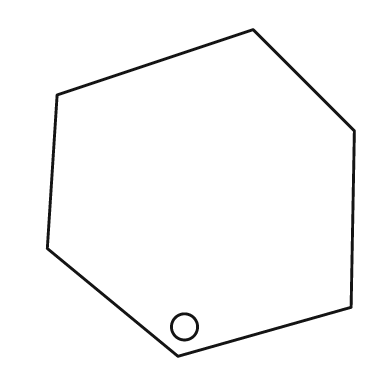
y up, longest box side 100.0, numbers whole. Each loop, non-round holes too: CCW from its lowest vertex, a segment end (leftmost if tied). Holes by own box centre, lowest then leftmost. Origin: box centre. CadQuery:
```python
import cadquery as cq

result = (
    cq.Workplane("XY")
    .moveTo(-7.0, -50.0)
    .lineTo(46.0, -35.0)
    .lineTo(47.0, 19.0)
    .lineTo(16.0, 50.0)
    .lineTo(-44.0, 30.0)
    .lineTo(-47.0, -17.0)
    .close()
    .moveTo(-5.0, -41.0)
    .circle(4.0)
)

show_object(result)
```